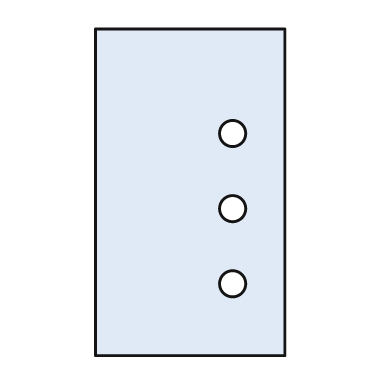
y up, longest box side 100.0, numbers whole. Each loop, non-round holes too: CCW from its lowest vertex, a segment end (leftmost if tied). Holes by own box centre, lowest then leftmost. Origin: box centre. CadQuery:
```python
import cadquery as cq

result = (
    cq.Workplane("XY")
    .moveTo(-29.0, -50.0)
    .lineTo(29.0, -50.0)
    .lineTo(29.0, 50.0)
    .lineTo(-29.0, 50.0)
    .close()
    .moveTo(13.0, -28.0)
    .circle(4.0)
    .moveTo(13.0, -5.0)
    .circle(4.0)
    .moveTo(13.0, 18.0)
    .circle(4.0)
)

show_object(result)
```